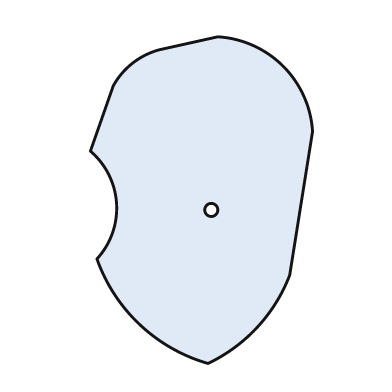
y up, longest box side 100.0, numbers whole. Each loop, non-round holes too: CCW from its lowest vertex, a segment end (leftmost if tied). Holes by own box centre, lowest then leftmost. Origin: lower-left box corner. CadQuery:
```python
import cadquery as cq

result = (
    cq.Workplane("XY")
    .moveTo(36.0, 0.0)
    .threePointArc((51.0, 11.0), (61.0, 27.0))
    .lineTo(68.0, 71.0)
    .threePointArc((59.0, 91.0), (39.0, 100.0))
    .lineTo(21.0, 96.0)
    .threePointArc((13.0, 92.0), (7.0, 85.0))
    .lineTo(0.0, 65.0)
    .threePointArc((8.0, 49.0), (2.0, 32.0))
    .threePointArc((15.0, 12.0), (36.0, 0.0))
    .close()
    .moveTo(37.0, 47.0)
    .circle(2.0)
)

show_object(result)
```